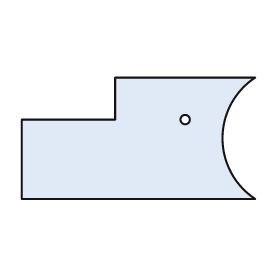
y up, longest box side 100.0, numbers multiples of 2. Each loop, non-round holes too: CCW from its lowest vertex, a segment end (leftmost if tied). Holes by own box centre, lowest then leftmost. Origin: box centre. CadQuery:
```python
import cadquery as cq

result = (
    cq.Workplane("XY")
    .moveTo(-50.0, -26.0)
    .lineTo(50.0, -26.0)
    .threePointArc((36.0, 0.0), (50.0, 26.0))
    .lineTo(-10.0, 26.0)
    .lineTo(-10.0, 8.0)
    .lineTo(-50.0, 8.0)
    .close()
    .moveTo(20.0, 8.0)
    .circle(2.0)
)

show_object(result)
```